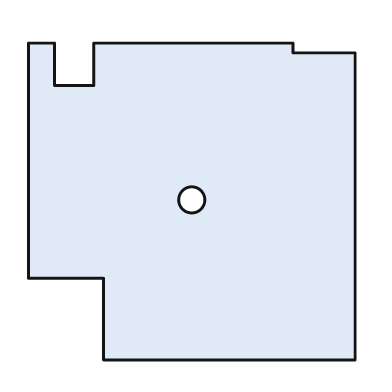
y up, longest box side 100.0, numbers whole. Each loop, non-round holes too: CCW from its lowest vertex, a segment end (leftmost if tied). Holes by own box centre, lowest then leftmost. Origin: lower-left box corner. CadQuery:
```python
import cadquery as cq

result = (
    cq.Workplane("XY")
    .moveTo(23.0, 0.0)
    .lineTo(100.0, 0.0)
    .lineTo(100.0, 94.0)
    .lineTo(81.0, 94.0)
    .lineTo(81.0, 97.0)
    .lineTo(20.0, 97.0)
    .lineTo(20.0, 84.0)
    .lineTo(8.0, 84.0)
    .lineTo(8.0, 97.0)
    .lineTo(0.0, 97.0)
    .lineTo(0.0, 25.0)
    .lineTo(23.0, 25.0)
    .close()
    .moveTo(50.0, 49.0)
    .circle(4.0)
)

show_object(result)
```